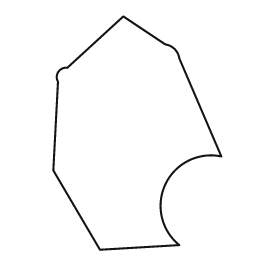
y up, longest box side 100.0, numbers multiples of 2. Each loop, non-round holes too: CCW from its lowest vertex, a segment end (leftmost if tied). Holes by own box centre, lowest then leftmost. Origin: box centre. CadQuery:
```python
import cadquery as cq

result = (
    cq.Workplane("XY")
    .moveTo(-16.0, -50.0)
    .lineTo(18.0, -48.0)
    .threePointArc((12.0, -22.0), (36.0, -10.0))
    .lineTo(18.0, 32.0)
    .threePointArc((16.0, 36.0), (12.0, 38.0))
    .lineTo(-6.0, 50.0)
    .lineTo(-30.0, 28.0)
    .threePointArc((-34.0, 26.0), (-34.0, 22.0))
    .lineTo(-36.0, -16.0)
    .close()
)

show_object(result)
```